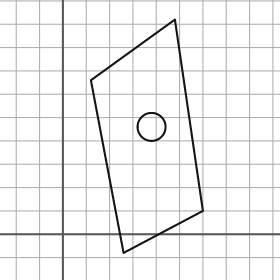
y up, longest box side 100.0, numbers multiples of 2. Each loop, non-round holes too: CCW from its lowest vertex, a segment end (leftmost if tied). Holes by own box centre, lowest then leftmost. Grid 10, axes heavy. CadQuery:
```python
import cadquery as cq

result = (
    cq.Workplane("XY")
    .moveTo(26.0, -8.0)
    .lineTo(60.0, 10.0)
    .lineTo(48.0, 92.0)
    .lineTo(12.0, 66.0)
    .close()
    .moveTo(38.0, 46.0)
    .circle(6.0)
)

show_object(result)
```